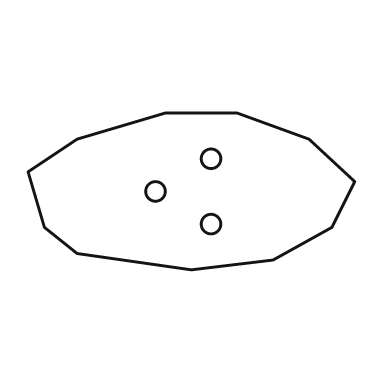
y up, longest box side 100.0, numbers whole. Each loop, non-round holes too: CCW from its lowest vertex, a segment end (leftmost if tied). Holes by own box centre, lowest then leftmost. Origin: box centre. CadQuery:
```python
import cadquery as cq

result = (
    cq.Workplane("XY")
    .moveTo(0.0, -24.0)
    .lineTo(25.0, -21.0)
    .lineTo(43.0, -11.0)
    .lineTo(50.0, 3.0)
    .lineTo(36.0, 16.0)
    .lineTo(14.0, 24.0)
    .lineTo(-8.0, 24.0)
    .lineTo(-35.0, 16.0)
    .lineTo(-50.0, 6.0)
    .lineTo(-45.0, -11.0)
    .lineTo(-35.0, -19.0)
    .close()
    .moveTo(6.0, -10.0)
    .circle(3.0)
    .moveTo(-11.0, 0.0)
    .circle(3.0)
    .moveTo(6.0, 10.0)
    .circle(3.0)
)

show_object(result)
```